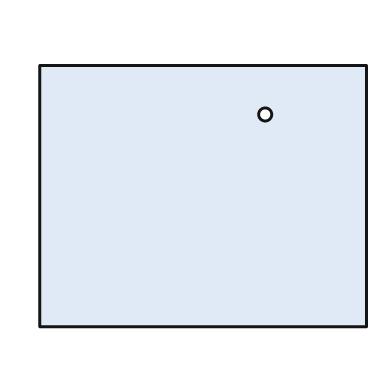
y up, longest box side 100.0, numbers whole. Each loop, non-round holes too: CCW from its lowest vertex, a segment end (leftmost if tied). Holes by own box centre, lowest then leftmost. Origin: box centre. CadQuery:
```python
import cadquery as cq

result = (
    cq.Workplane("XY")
    .moveTo(-50.0, -40.0)
    .lineTo(50.0, -40.0)
    .lineTo(50.0, 40.0)
    .lineTo(-50.0, 40.0)
    .close()
    .moveTo(19.0, 25.0)
    .circle(2.0)
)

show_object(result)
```